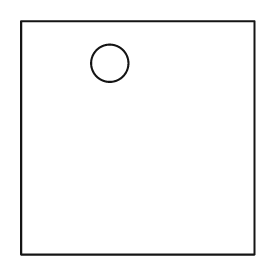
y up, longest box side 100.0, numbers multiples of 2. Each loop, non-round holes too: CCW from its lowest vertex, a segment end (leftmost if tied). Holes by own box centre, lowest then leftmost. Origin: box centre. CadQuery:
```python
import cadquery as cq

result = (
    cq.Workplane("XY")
    .moveTo(-50.0, -50.0)
    .lineTo(50.0, -50.0)
    .lineTo(50.0, 50.0)
    .lineTo(-50.0, 50.0)
    .close()
    .moveTo(-12.0, 32.0)
    .circle(8.0)
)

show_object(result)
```